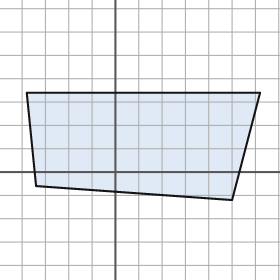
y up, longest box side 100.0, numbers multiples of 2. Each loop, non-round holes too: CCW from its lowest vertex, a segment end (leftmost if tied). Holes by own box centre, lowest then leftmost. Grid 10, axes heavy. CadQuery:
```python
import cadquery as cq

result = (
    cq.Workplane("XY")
    .moveTo(50.0, -12.0)
    .lineTo(62.0, 34.0)
    .lineTo(-38.0, 34.0)
    .lineTo(-34.0, -6.0)
    .close()
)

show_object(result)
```